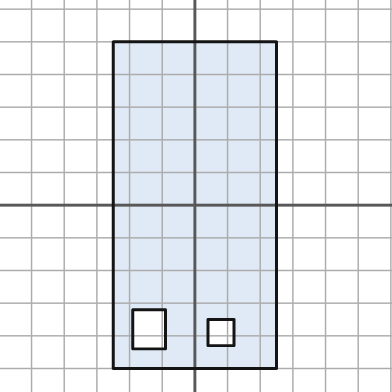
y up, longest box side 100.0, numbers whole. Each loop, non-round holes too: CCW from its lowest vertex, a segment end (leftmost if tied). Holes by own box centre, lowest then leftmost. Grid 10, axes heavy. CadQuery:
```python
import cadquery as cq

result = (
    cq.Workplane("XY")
    .moveTo(-25.0, -50.0)
    .lineTo(25.0, -50.0)
    .lineTo(25.0, 50.0)
    .lineTo(-25.0, 50.0)
    .close()
    .moveTo(4.0, -43.0)
    .lineTo(12.0, -43.0)
    .lineTo(12.0, -35.0)
    .lineTo(4.0, -35.0)
    .close()
    .moveTo(-19.0, -44.0)
    .lineTo(-9.0, -44.0)
    .lineTo(-9.0, -32.0)
    .lineTo(-19.0, -32.0)
    .close()
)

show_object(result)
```